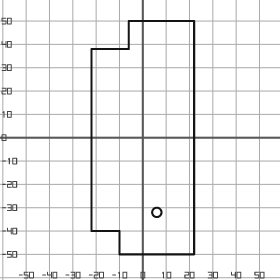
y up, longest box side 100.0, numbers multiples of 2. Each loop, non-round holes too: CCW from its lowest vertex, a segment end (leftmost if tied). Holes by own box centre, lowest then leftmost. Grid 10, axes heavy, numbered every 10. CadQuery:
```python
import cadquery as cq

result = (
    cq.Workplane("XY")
    .moveTo(-10.0, -50.0)
    .lineTo(22.0, -50.0)
    .lineTo(22.0, 50.0)
    .lineTo(-6.0, 50.0)
    .lineTo(-6.0, 38.0)
    .lineTo(-22.0, 38.0)
    .lineTo(-22.0, -40.0)
    .lineTo(-10.0, -40.0)
    .close()
    .moveTo(6.0, -32.0)
    .circle(2.0)
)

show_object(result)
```